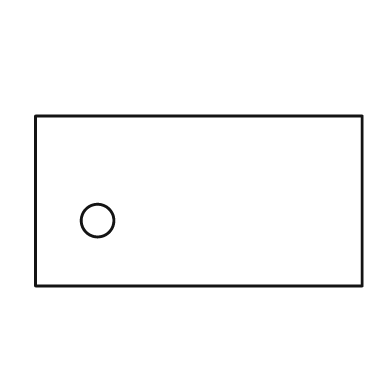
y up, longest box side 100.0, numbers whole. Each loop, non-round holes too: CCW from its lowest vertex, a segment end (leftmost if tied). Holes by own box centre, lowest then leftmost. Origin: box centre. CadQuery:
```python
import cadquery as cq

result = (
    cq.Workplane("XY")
    .moveTo(-50.0, -26.0)
    .lineTo(50.0, -26.0)
    .lineTo(50.0, 26.0)
    .lineTo(-50.0, 26.0)
    .close()
    .moveTo(-31.0, -6.0)
    .circle(5.0)
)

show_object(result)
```